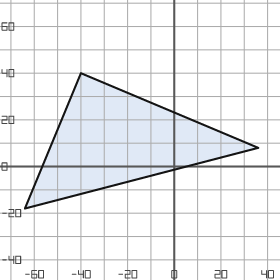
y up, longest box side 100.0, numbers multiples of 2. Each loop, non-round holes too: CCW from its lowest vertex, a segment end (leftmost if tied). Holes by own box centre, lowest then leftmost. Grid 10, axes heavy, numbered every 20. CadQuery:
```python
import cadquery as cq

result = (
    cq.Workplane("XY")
    .moveTo(-64.0, -18.0)
    .lineTo(36.0, 8.0)
    .lineTo(-40.0, 40.0)
    .close()
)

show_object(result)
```